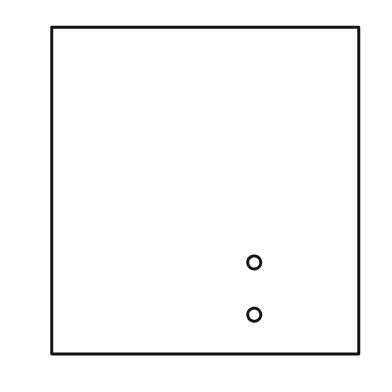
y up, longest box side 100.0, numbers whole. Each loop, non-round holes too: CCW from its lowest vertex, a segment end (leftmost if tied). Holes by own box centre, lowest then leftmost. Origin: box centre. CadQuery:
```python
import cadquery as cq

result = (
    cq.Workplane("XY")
    .moveTo(-47.0, -50.0)
    .lineTo(47.0, -50.0)
    .lineTo(47.0, 50.0)
    .lineTo(-47.0, 50.0)
    .close()
    .moveTo(15.0, -38.0)
    .circle(2.0)
    .moveTo(15.0, -22.0)
    .circle(2.0)
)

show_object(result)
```